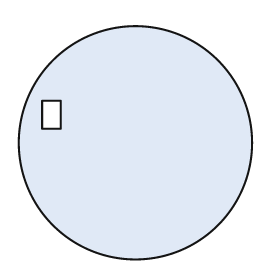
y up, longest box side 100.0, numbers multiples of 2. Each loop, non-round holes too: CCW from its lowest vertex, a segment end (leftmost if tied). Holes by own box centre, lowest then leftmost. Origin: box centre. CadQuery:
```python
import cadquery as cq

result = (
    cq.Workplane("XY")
    .moveTo(0.0, 0.0)
    .circle(50.0)
    .moveTo(-40.0, 6.0)
    .lineTo(-32.0, 6.0)
    .lineTo(-32.0, 18.0)
    .lineTo(-40.0, 18.0)
    .close()
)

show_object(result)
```